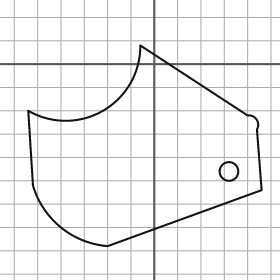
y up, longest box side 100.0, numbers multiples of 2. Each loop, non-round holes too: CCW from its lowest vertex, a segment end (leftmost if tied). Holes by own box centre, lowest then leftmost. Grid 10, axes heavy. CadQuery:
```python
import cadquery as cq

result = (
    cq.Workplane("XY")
    .moveTo(-20.0, -78.0)
    .lineTo(46.0, -54.0)
    .lineTo(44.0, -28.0)
    .threePointArc((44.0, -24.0), (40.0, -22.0))
    .lineTo(-6.0, 8.0)
    .threePointArc((-22.0, -20.0), (-54.0, -20.0))
    .lineTo(-52.0, -52.0)
    .threePointArc((-40.0, -70.0), (-20.0, -78.0))
    .close()
    .moveTo(32.0, -46.0)
    .circle(4.0)
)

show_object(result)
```